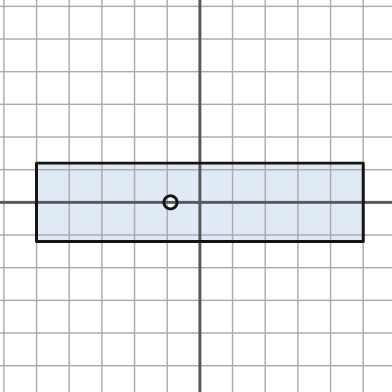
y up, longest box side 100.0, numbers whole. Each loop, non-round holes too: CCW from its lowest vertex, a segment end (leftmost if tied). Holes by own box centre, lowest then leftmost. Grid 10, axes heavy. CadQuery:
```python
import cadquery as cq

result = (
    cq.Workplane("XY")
    .moveTo(-50.0, -12.0)
    .lineTo(50.0, -12.0)
    .lineTo(50.0, 12.0)
    .lineTo(-50.0, 12.0)
    .close()
    .moveTo(-9.0, 0.0)
    .circle(2.0)
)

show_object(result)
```